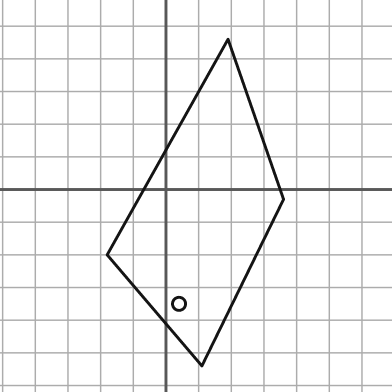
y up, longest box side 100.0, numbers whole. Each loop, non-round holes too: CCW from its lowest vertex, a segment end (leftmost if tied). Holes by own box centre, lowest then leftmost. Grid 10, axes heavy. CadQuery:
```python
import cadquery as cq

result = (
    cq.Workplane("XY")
    .moveTo(11.0, -54.0)
    .lineTo(36.0, -3.0)
    .lineTo(19.0, 46.0)
    .lineTo(-18.0, -20.0)
    .close()
    .moveTo(4.0, -35.0)
    .circle(2.0)
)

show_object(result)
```